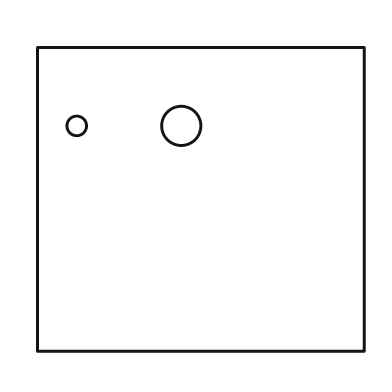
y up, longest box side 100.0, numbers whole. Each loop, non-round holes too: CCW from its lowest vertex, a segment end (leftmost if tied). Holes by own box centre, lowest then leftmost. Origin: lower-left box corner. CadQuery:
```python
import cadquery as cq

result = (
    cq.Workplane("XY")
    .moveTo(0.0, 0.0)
    .lineTo(100.0, 0.0)
    .lineTo(100.0, 93.0)
    .lineTo(0.0, 93.0)
    .close()
    .moveTo(12.0, 69.0)
    .circle(3.0)
    .moveTo(44.0, 69.0)
    .circle(6.0)
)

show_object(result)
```